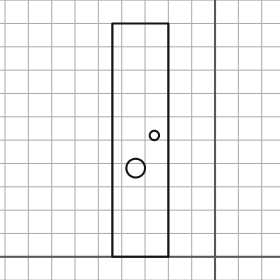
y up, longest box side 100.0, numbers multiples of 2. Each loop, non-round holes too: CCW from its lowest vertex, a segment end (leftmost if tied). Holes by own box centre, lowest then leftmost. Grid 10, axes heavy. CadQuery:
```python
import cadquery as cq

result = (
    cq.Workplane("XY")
    .moveTo(-44.0, 0.0)
    .lineTo(-20.0, 0.0)
    .lineTo(-20.0, 100.0)
    .lineTo(-44.0, 100.0)
    .close()
    .moveTo(-34.0, 38.0)
    .circle(4.0)
    .moveTo(-26.0, 52.0)
    .circle(2.0)
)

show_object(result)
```